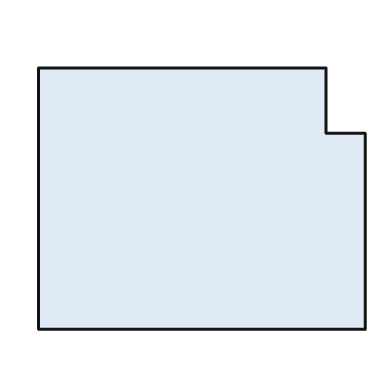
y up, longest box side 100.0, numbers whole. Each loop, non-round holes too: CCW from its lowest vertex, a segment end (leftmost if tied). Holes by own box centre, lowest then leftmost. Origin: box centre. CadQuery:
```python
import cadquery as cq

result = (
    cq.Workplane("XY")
    .moveTo(-50.0, -40.0)
    .lineTo(50.0, -40.0)
    .lineTo(50.0, 20.0)
    .lineTo(38.0, 20.0)
    .lineTo(38.0, 40.0)
    .lineTo(-50.0, 40.0)
    .close()
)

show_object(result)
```